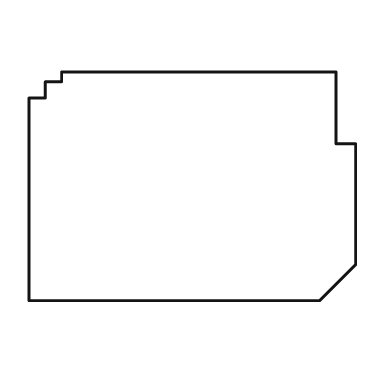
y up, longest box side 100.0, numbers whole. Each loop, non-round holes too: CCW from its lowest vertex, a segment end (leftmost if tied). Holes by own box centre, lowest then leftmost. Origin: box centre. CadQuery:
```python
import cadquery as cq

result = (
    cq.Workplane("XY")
    .moveTo(-50.0, -35.0)
    .lineTo(39.0, -35.0)
    .lineTo(50.0, -24.0)
    .lineTo(50.0, 13.0)
    .lineTo(44.0, 13.0)
    .lineTo(44.0, 35.0)
    .lineTo(-40.0, 35.0)
    .lineTo(-40.0, 32.0)
    .lineTo(-45.0, 32.0)
    .lineTo(-45.0, 27.0)
    .lineTo(-50.0, 27.0)
    .close()
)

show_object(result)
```